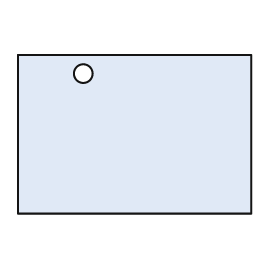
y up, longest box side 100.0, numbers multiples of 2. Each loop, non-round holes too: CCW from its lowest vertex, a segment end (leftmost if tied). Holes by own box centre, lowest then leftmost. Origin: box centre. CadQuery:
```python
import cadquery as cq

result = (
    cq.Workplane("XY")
    .moveTo(-50.0, -34.0)
    .lineTo(50.0, -34.0)
    .lineTo(50.0, 34.0)
    .lineTo(-50.0, 34.0)
    .close()
    .moveTo(-22.0, 26.0)
    .circle(4.0)
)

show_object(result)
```